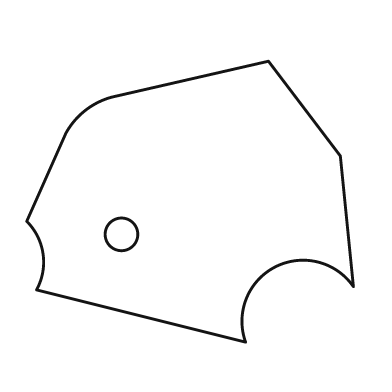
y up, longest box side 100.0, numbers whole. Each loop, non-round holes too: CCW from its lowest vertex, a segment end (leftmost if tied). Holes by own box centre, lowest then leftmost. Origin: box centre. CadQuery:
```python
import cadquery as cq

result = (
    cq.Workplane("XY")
    .moveTo(17.0, -43.0)
    .threePointArc((26.0, -20.0), (50.0, -26.0))
    .lineTo(46.0, 14.0)
    .lineTo(24.0, 43.0)
    .lineTo(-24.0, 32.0)
    .threePointArc((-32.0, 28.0), (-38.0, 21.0))
    .lineTo(-50.0, -6.0)
    .threePointArc((-45.0, -16.0), (-47.0, -27.0))
    .close()
    .moveTo(-21.0, -10.0)
    .circle(5.0)
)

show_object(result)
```